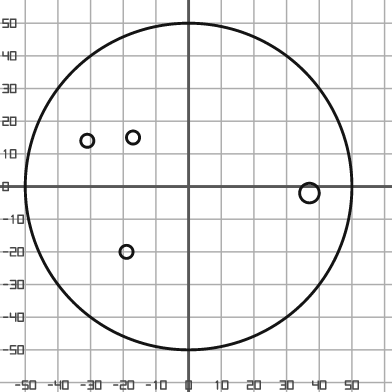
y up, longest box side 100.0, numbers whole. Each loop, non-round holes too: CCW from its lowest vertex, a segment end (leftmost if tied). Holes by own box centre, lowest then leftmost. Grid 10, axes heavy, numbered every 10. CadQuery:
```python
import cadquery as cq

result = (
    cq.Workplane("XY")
    .moveTo(0.0, 0.0)
    .circle(50.0)
    .moveTo(-19.0, -20.0)
    .circle(2.0)
    .moveTo(37.0, -2.0)
    .circle(3.0)
    .moveTo(-31.0, 14.0)
    .circle(2.0)
    .moveTo(-17.0, 15.0)
    .circle(2.0)
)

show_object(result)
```